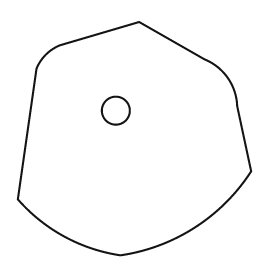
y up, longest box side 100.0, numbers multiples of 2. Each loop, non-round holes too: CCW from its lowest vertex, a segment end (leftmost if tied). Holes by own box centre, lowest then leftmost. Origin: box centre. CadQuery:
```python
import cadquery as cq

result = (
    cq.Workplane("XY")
    .moveTo(-6.0, -50.0)
    .threePointArc((26.0, -38.0), (50.0, -14.0))
    .lineTo(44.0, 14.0)
    .threePointArc((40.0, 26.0), (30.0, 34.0))
    .lineTo(2.0, 50.0)
    .lineTo(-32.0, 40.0)
    .threePointArc((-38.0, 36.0), (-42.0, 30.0))
    .lineTo(-50.0, -26.0)
    .threePointArc((-30.0, -42.0), (-6.0, -50.0))
    .close()
    .moveTo(-8.0, 12.0)
    .circle(6.0)
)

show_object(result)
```